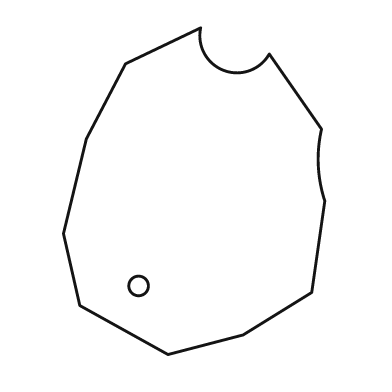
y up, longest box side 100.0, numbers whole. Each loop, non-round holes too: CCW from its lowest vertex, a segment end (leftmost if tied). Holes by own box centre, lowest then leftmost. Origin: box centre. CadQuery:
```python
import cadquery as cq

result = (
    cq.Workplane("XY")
    .moveTo(-8.0, -50.0)
    .lineTo(15.0, -44.0)
    .lineTo(36.0, -31.0)
    .lineTo(40.0, -3.0)
    .threePointArc((38.0, 8.0), (39.0, 19.0))
    .lineTo(23.0, 42.0)
    .threePointArc((9.0, 37.0), (2.0, 50.0))
    .lineTo(-21.0, 39.0)
    .lineTo(-33.0, 16.0)
    .lineTo(-40.0, -13.0)
    .lineTo(-35.0, -35.0)
    .close()
    .moveTo(-17.0, -29.0)
    .circle(3.0)
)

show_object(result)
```